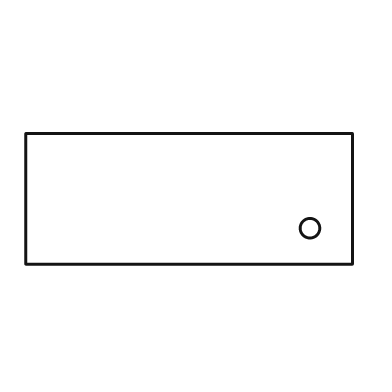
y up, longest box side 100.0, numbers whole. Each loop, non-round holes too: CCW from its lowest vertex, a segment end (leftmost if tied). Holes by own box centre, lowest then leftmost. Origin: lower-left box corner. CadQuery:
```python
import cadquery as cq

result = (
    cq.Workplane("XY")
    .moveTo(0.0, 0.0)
    .lineTo(100.0, 0.0)
    .lineTo(100.0, 40.0)
    .lineTo(0.0, 40.0)
    .close()
    .moveTo(87.0, 11.0)
    .circle(3.0)
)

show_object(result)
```